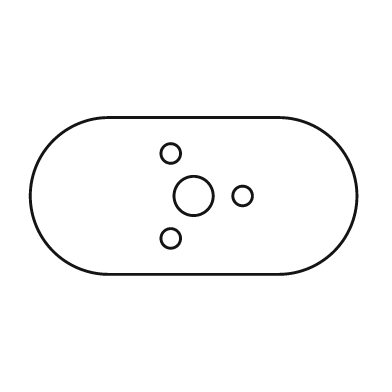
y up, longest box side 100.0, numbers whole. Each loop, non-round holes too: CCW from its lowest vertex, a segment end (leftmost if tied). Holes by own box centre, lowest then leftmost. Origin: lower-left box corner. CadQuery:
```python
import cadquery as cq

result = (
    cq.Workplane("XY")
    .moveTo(24.0, 0.0)
    .lineTo(76.0, 0.0)
    .threePointArc((100.0, 24.0), (76.0, 48.0))
    .lineTo(24.0, 48.0)
    .threePointArc((0.0, 24.0), (24.0, 0.0))
    .close()
    .moveTo(43.0, 11.0)
    .circle(3.0)
    .moveTo(50.0, 24.0)
    .circle(6.0)
    .moveTo(65.0, 24.0)
    .circle(3.0)
    .moveTo(43.0, 37.0)
    .circle(3.0)
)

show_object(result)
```